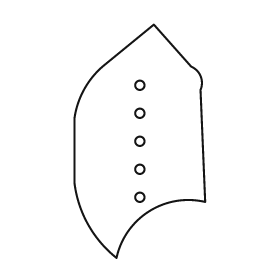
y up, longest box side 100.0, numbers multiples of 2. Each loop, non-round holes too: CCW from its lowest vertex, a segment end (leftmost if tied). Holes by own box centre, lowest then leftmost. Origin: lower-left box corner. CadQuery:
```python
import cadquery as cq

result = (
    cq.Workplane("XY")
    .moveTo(18.0, 0.0)
    .threePointArc((32.0, 20.0), (56.0, 24.0))
    .lineTo(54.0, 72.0)
    .threePointArc((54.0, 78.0), (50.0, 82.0))
    .lineTo(34.0, 100.0)
    .lineTo(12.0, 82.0)
    .threePointArc((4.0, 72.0), (0.0, 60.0))
    .lineTo(0.0, 32.0)
    .threePointArc((6.0, 14.0), (18.0, 0.0))
    .close()
    .moveTo(28.0, 26.0)
    .circle(2.0)
    .moveTo(28.0, 38.0)
    .circle(2.0)
    .moveTo(28.0, 50.0)
    .circle(2.0)
    .moveTo(28.0, 62.0)
    .circle(2.0)
    .moveTo(28.0, 74.0)
    .circle(2.0)
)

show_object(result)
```